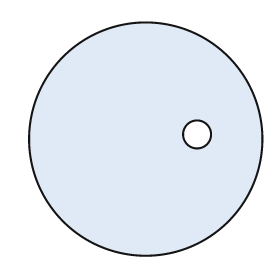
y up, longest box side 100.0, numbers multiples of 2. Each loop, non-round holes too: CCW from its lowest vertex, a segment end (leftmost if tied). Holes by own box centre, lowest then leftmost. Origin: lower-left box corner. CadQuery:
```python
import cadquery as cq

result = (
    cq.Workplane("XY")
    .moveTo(50.0, 50.0)
    .circle(50.0)
    .moveTo(72.0, 52.0)
    .circle(6.0)
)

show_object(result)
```